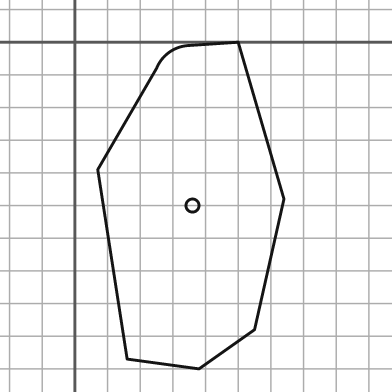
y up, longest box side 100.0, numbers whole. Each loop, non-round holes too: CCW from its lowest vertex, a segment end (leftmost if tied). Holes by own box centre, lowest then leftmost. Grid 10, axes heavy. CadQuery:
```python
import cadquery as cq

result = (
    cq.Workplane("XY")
    .moveTo(38.0, -100.0)
    .lineTo(55.0, -88.0)
    .lineTo(64.0, -48.0)
    .lineTo(50.0, 0.0)
    .lineTo(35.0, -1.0)
    .threePointArc((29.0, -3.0), (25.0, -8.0))
    .lineTo(7.0, -39.0)
    .lineTo(16.0, -97.0)
    .close()
    .moveTo(36.0, -50.0)
    .circle(2.0)
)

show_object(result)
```